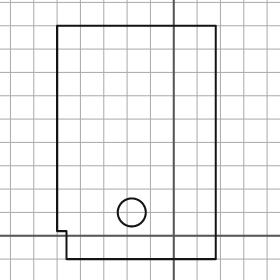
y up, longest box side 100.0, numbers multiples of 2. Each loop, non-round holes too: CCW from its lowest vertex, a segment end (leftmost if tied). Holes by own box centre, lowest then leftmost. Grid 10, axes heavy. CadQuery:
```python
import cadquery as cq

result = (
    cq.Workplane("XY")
    .moveTo(-46.0, -10.0)
    .lineTo(18.0, -10.0)
    .lineTo(18.0, 90.0)
    .lineTo(-50.0, 90.0)
    .lineTo(-50.0, 2.0)
    .lineTo(-46.0, 2.0)
    .close()
    .moveTo(-18.0, 10.0)
    .circle(6.0)
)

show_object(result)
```